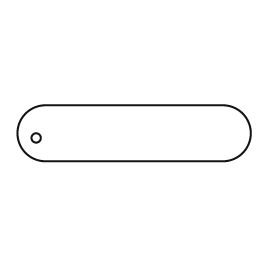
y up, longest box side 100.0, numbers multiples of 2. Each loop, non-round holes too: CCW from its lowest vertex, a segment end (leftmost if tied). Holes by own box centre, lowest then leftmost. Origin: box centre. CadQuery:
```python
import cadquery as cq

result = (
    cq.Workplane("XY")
    .moveTo(-38.0, -12.0)
    .lineTo(38.0, -12.0)
    .threePointArc((50.0, 0.0), (38.0, 12.0))
    .lineTo(-38.0, 12.0)
    .threePointArc((-50.0, 0.0), (-38.0, -12.0))
    .close()
    .moveTo(-42.0, -2.0)
    .circle(2.0)
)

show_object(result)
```